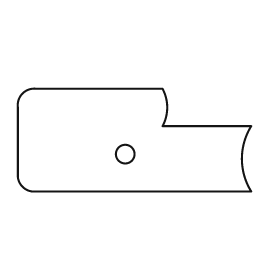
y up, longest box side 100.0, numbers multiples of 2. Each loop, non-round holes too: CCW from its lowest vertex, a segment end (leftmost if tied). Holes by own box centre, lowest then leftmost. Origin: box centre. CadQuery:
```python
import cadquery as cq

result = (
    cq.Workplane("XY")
    .moveTo(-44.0, -22.0)
    .lineTo(50.0, -22.0)
    .threePointArc((46.0, -8.0), (50.0, 6.0))
    .lineTo(12.0, 6.0)
    .threePointArc((14.0, 14.0), (12.0, 22.0))
    .lineTo(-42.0, 22.0)
    .threePointArc((-48.0, 20.0), (-50.0, 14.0))
    .lineTo(-50.0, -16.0)
    .threePointArc((-48.0, -20.0), (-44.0, -22.0))
    .close()
    .moveTo(-4.0, -6.0)
    .circle(4.0)
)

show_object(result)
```